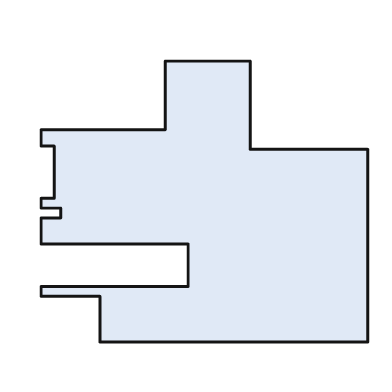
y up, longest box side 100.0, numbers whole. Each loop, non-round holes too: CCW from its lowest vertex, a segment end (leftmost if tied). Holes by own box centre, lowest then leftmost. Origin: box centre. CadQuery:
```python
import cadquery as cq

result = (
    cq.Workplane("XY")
    .moveTo(-32.0, -43.0)
    .lineTo(50.0, -43.0)
    .lineTo(50.0, 16.0)
    .lineTo(14.0, 16.0)
    .lineTo(14.0, 43.0)
    .lineTo(-12.0, 43.0)
    .lineTo(-12.0, 22.0)
    .lineTo(-50.0, 22.0)
    .lineTo(-50.0, 17.0)
    .lineTo(-46.0, 17.0)
    .lineTo(-46.0, 1.0)
    .lineTo(-50.0, 1.0)
    .lineTo(-50.0, -2.0)
    .lineTo(-44.0, -2.0)
    .lineTo(-44.0, -5.0)
    .lineTo(-50.0, -5.0)
    .lineTo(-50.0, -13.0)
    .lineTo(-5.0, -13.0)
    .lineTo(-5.0, -26.0)
    .lineTo(-50.0, -26.0)
    .lineTo(-50.0, -29.0)
    .lineTo(-32.0, -29.0)
    .close()
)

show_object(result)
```